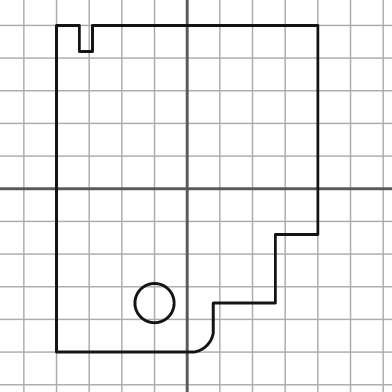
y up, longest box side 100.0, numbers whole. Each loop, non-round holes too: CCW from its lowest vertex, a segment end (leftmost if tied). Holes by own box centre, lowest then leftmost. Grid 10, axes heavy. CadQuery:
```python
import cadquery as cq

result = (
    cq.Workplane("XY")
    .moveTo(-40.0, -50.0)
    .lineTo(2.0, -50.0)
    .threePointArc((6.0, -48.0), (8.0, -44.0))
    .lineTo(8.0, -35.0)
    .lineTo(27.0, -35.0)
    .lineTo(27.0, -14.0)
    .lineTo(40.0, -14.0)
    .lineTo(40.0, 50.0)
    .lineTo(-29.0, 50.0)
    .lineTo(-29.0, 42.0)
    .lineTo(-33.0, 42.0)
    .lineTo(-33.0, 50.0)
    .lineTo(-40.0, 50.0)
    .close()
    .moveTo(-10.0, -35.0)
    .circle(6.0)
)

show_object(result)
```